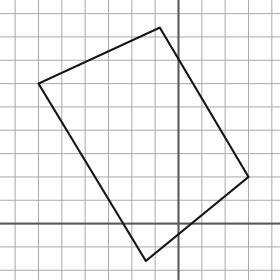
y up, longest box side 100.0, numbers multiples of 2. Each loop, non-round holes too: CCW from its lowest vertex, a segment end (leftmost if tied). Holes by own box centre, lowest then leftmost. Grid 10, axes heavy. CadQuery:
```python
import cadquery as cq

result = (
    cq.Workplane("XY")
    .moveTo(-14.0, -16.0)
    .lineTo(30.0, 20.0)
    .lineTo(-8.0, 84.0)
    .lineTo(-60.0, 60.0)
    .close()
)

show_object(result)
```